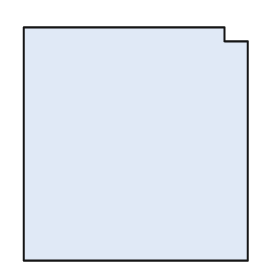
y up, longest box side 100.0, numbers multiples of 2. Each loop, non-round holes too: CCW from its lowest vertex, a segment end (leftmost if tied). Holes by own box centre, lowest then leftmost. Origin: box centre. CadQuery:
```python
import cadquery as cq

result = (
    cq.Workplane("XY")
    .moveTo(-48.0, -50.0)
    .lineTo(48.0, -50.0)
    .lineTo(48.0, 44.0)
    .lineTo(38.0, 44.0)
    .lineTo(38.0, 50.0)
    .lineTo(-48.0, 50.0)
    .close()
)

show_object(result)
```